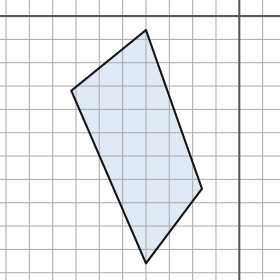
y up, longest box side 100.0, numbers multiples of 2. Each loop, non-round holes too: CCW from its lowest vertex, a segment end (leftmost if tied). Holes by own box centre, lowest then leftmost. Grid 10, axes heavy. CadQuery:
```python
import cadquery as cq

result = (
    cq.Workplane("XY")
    .moveTo(-40.0, -106.0)
    .lineTo(-16.0, -74.0)
    .lineTo(-40.0, -6.0)
    .lineTo(-72.0, -32.0)
    .close()
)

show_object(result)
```